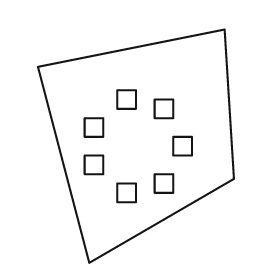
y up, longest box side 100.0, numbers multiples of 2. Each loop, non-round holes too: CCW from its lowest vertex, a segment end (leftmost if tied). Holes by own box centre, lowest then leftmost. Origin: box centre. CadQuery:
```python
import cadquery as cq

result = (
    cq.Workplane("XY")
    .moveTo(-20.0, -50.0)
    .lineTo(42.0, -14.0)
    .lineTo(38.0, 50.0)
    .lineTo(-42.0, 34.0)
    .close()
    .moveTo(-8.0, -24.0)
    .lineTo(0.0, -24.0)
    .lineTo(0.0, -16.0)
    .lineTo(-8.0, -16.0)
    .close()
    .moveTo(8.0, -20.0)
    .lineTo(16.0, -20.0)
    .lineTo(16.0, -12.0)
    .lineTo(8.0, -12.0)
    .close()
    .moveTo(-22.0, -12.0)
    .lineTo(-14.0, -12.0)
    .lineTo(-14.0, -4.0)
    .lineTo(-22.0, -4.0)
    .close()
    .moveTo(16.0, -4.0)
    .lineTo(24.0, -4.0)
    .lineTo(24.0, 4.0)
    .lineTo(16.0, 4.0)
    .close()
    .moveTo(-22.0, 4.0)
    .lineTo(-14.0, 4.0)
    .lineTo(-14.0, 12.0)
    .lineTo(-22.0, 12.0)
    .close()
    .moveTo(8.0, 12.0)
    .lineTo(16.0, 12.0)
    .lineTo(16.0, 20.0)
    .lineTo(8.0, 20.0)
    .close()
    .moveTo(-8.0, 16.0)
    .lineTo(0.0, 16.0)
    .lineTo(0.0, 24.0)
    .lineTo(-8.0, 24.0)
    .close()
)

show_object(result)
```